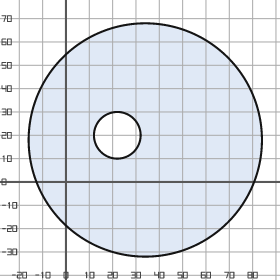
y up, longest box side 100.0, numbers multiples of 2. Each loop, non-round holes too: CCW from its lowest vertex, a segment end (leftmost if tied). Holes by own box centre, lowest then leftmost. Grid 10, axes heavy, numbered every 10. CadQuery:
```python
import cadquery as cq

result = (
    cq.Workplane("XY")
    .moveTo(34.0, 18.0)
    .circle(50.0)
    .moveTo(22.0, 20.0)
    .circle(10.0)
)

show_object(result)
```